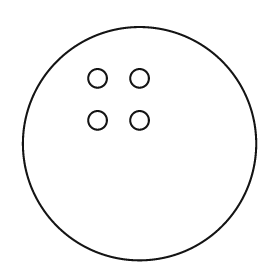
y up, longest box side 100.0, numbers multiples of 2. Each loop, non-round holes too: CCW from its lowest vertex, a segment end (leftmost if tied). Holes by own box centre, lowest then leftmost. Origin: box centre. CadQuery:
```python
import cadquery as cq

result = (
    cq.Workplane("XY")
    .moveTo(0.0, 0.0)
    .circle(50.0)
    .moveTo(-18.0, 10.0)
    .circle(4.0)
    .moveTo(0.0, 10.0)
    .circle(4.0)
    .moveTo(-18.0, 28.0)
    .circle(4.0)
    .moveTo(0.0, 28.0)
    .circle(4.0)
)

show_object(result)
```